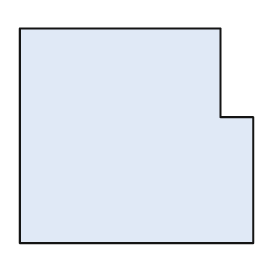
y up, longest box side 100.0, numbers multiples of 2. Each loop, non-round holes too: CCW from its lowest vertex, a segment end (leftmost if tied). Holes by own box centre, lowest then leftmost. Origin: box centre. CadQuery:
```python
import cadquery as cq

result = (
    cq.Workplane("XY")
    .moveTo(-50.0, -46.0)
    .lineTo(50.0, -46.0)
    .lineTo(50.0, 8.0)
    .lineTo(36.0, 8.0)
    .lineTo(36.0, 46.0)
    .lineTo(-50.0, 46.0)
    .close()
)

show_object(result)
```